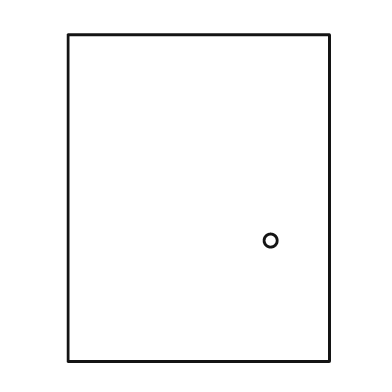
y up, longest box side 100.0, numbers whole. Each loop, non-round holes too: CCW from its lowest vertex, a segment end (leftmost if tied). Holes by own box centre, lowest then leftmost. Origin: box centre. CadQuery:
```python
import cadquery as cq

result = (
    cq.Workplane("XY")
    .moveTo(-40.0, -50.0)
    .lineTo(40.0, -50.0)
    .lineTo(40.0, 50.0)
    .lineTo(-40.0, 50.0)
    .close()
    .moveTo(22.0, -13.0)
    .circle(2.0)
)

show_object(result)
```